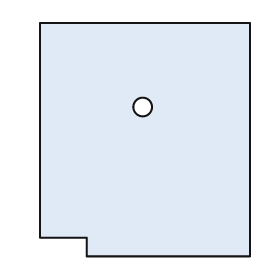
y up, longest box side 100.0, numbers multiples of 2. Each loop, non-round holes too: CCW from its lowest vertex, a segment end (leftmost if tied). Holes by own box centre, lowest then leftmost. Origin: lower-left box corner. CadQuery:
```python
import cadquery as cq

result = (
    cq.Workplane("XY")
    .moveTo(20.0, 0.0)
    .lineTo(90.0, 0.0)
    .lineTo(90.0, 100.0)
    .lineTo(0.0, 100.0)
    .lineTo(0.0, 8.0)
    .lineTo(20.0, 8.0)
    .close()
    .moveTo(44.0, 64.0)
    .circle(4.0)
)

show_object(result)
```